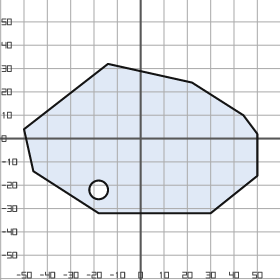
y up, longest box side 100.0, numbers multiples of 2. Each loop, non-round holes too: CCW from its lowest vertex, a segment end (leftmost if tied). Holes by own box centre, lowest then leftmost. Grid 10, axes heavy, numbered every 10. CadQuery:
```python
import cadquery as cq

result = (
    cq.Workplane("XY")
    .moveTo(-18.0, -32.0)
    .lineTo(30.0, -32.0)
    .lineTo(50.0, -16.0)
    .lineTo(50.0, 2.0)
    .lineTo(44.0, 10.0)
    .lineTo(22.0, 24.0)
    .lineTo(-14.0, 32.0)
    .lineTo(-50.0, 4.0)
    .lineTo(-46.0, -14.0)
    .close()
    .moveTo(-18.0, -22.0)
    .circle(4.0)
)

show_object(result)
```